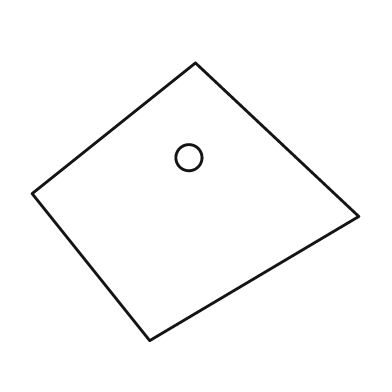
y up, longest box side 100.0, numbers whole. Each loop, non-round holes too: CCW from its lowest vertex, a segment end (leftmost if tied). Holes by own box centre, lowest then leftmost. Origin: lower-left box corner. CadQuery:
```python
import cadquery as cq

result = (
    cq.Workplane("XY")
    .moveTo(36.0, 0.0)
    .lineTo(100.0, 38.0)
    .lineTo(50.0, 85.0)
    .lineTo(0.0, 45.0)
    .close()
    .moveTo(48.0, 56.0)
    .circle(4.0)
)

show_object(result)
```